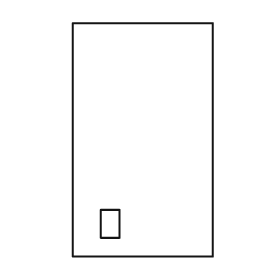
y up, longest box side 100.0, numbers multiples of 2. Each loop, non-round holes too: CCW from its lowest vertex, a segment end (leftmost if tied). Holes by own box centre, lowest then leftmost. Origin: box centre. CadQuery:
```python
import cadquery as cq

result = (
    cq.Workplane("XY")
    .moveTo(-30.0, -50.0)
    .lineTo(30.0, -50.0)
    .lineTo(30.0, 50.0)
    .lineTo(-30.0, 50.0)
    .close()
    .moveTo(-18.0, -42.0)
    .lineTo(-10.0, -42.0)
    .lineTo(-10.0, -30.0)
    .lineTo(-18.0, -30.0)
    .close()
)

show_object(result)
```